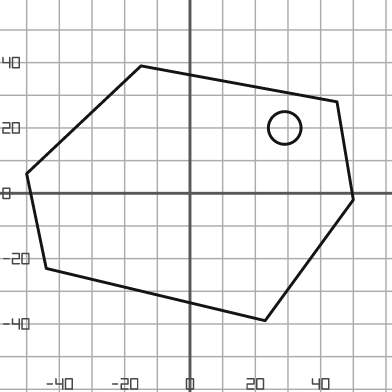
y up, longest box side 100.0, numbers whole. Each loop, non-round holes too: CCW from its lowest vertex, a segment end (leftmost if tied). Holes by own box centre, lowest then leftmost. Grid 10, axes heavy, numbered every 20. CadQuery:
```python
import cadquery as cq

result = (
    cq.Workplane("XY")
    .moveTo(23.0, -39.0)
    .lineTo(50.0, -2.0)
    .lineTo(45.0, 28.0)
    .lineTo(-15.0, 39.0)
    .lineTo(-50.0, 6.0)
    .lineTo(-44.0, -23.0)
    .close()
    .moveTo(29.0, 20.0)
    .circle(5.0)
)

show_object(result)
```